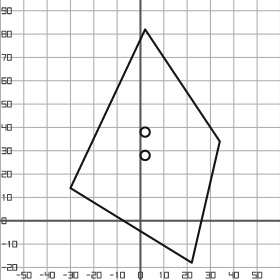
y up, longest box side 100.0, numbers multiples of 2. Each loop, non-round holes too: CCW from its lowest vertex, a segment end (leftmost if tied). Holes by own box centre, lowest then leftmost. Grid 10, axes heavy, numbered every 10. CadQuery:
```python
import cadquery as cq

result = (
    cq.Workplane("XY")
    .moveTo(22.0, -18.0)
    .lineTo(34.0, 34.0)
    .lineTo(2.0, 82.0)
    .lineTo(-30.0, 14.0)
    .close()
    .moveTo(2.0, 28.0)
    .circle(2.0)
    .moveTo(2.0, 38.0)
    .circle(2.0)
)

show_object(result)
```